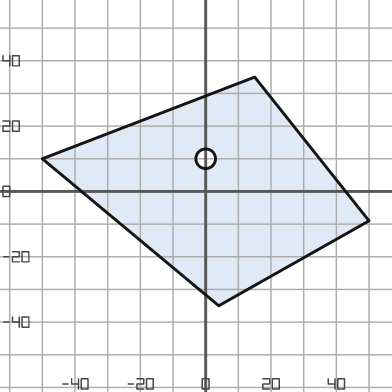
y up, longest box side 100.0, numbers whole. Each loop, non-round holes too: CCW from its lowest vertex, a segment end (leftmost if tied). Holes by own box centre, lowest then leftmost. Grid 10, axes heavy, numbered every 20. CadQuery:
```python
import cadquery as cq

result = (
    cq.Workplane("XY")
    .moveTo(4.0, -35.0)
    .lineTo(50.0, -9.0)
    .lineTo(15.0, 35.0)
    .lineTo(-50.0, 10.0)
    .close()
    .moveTo(0.0, 10.0)
    .circle(3.0)
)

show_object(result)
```